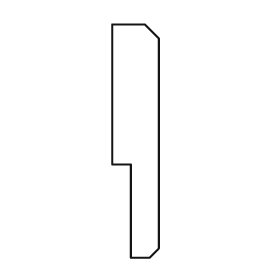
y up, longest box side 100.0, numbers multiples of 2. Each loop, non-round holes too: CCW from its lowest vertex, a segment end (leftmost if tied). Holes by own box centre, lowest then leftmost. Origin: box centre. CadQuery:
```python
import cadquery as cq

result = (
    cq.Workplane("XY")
    .moveTo(-2.0, -50.0)
    .lineTo(6.0, -50.0)
    .lineTo(10.0, -46.0)
    .lineTo(10.0, 44.0)
    .lineTo(4.0, 50.0)
    .lineTo(-10.0, 50.0)
    .lineTo(-10.0, -10.0)
    .lineTo(-2.0, -10.0)
    .close()
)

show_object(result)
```